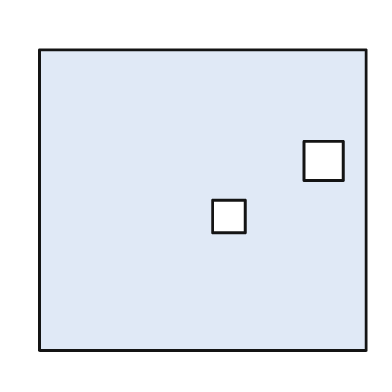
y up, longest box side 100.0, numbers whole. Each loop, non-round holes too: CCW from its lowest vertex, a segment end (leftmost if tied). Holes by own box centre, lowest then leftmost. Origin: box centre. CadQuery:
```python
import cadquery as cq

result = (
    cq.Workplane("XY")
    .moveTo(-50.0, -46.0)
    .lineTo(50.0, -46.0)
    .lineTo(50.0, 46.0)
    .lineTo(-50.0, 46.0)
    .close()
    .moveTo(3.0, -10.0)
    .lineTo(13.0, -10.0)
    .lineTo(13.0, 0.0)
    .lineTo(3.0, 0.0)
    .close()
    .moveTo(31.0, 6.0)
    .lineTo(43.0, 6.0)
    .lineTo(43.0, 18.0)
    .lineTo(31.0, 18.0)
    .close()
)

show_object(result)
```